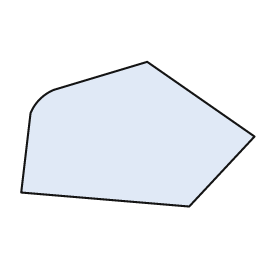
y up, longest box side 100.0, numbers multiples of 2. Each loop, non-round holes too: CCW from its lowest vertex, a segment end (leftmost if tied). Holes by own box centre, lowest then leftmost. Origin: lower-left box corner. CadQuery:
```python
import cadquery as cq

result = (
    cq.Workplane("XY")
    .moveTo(72.0, 0.0)
    .lineTo(100.0, 30.0)
    .lineTo(54.0, 62.0)
    .lineTo(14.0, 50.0)
    .threePointArc((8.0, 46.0), (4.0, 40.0))
    .lineTo(0.0, 6.0)
    .close()
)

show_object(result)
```